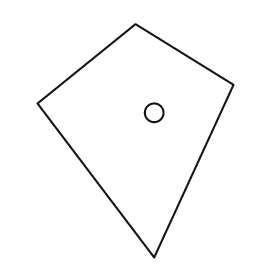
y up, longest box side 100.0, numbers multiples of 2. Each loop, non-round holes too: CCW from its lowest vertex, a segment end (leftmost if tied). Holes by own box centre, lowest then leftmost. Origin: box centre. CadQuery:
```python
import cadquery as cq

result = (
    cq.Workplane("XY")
    .moveTo(8.0, -50.0)
    .lineTo(42.0, 24.0)
    .lineTo(0.0, 50.0)
    .lineTo(-42.0, 16.0)
    .close()
    .moveTo(8.0, 12.0)
    .circle(4.0)
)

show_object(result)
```